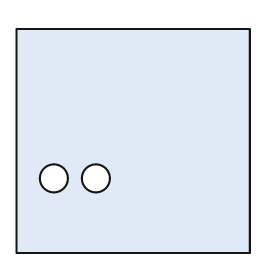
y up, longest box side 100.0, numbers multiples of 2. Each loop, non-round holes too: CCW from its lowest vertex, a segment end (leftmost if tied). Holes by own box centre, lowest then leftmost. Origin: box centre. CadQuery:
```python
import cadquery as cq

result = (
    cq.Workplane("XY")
    .moveTo(-50.0, -48.0)
    .lineTo(50.0, -48.0)
    .lineTo(50.0, 48.0)
    .lineTo(-50.0, 48.0)
    .close()
    .moveTo(-34.0, -16.0)
    .circle(6.0)
    .moveTo(-16.0, -16.0)
    .circle(6.0)
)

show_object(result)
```